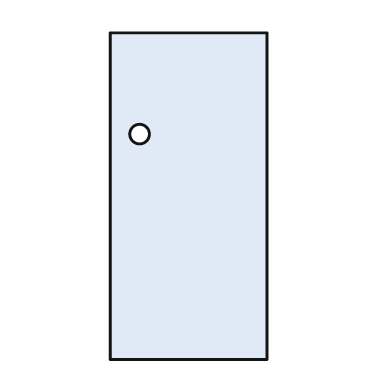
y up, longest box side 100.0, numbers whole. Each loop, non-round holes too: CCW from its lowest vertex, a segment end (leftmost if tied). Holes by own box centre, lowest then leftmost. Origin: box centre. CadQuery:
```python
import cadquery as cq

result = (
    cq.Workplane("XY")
    .moveTo(-24.0, -50.0)
    .lineTo(24.0, -50.0)
    .lineTo(24.0, 50.0)
    .lineTo(-24.0, 50.0)
    .close()
    .moveTo(-15.0, 19.0)
    .circle(3.0)
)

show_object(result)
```